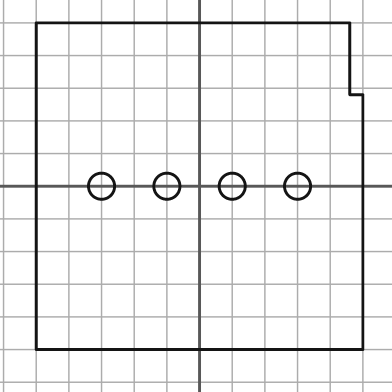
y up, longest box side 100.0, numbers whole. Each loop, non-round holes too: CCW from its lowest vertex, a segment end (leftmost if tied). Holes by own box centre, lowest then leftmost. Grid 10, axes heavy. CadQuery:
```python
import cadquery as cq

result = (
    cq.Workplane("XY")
    .moveTo(-50.0, -50.0)
    .lineTo(50.0, -50.0)
    .lineTo(50.0, 28.0)
    .lineTo(46.0, 28.0)
    .lineTo(46.0, 50.0)
    .lineTo(-50.0, 50.0)
    .close()
    .moveTo(-30.0, 0.0)
    .circle(4.0)
    .moveTo(-10.0, 0.0)
    .circle(4.0)
    .moveTo(10.0, 0.0)
    .circle(4.0)
    .moveTo(30.0, 0.0)
    .circle(4.0)
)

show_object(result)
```